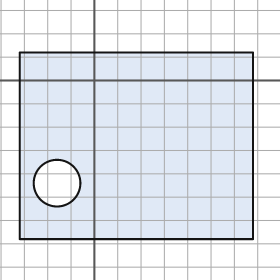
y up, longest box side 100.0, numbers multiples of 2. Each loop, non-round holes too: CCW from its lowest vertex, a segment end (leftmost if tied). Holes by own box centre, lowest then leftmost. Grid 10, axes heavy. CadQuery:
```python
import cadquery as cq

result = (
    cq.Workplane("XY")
    .moveTo(-32.0, -68.0)
    .lineTo(68.0, -68.0)
    .lineTo(68.0, 12.0)
    .lineTo(-32.0, 12.0)
    .close()
    .moveTo(-16.0, -44.0)
    .circle(10.0)
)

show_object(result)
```